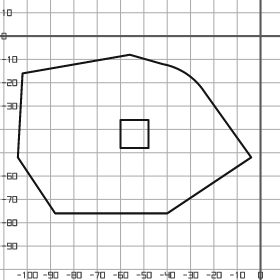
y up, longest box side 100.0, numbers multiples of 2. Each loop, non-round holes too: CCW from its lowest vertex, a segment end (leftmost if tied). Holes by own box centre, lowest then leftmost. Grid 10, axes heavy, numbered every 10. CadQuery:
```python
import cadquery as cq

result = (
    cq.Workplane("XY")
    .moveTo(-88.0, -76.0)
    .lineTo(-40.0, -76.0)
    .lineTo(-4.0, -52.0)
    .lineTo(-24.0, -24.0)
    .threePointArc((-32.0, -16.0), (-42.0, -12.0))
    .lineTo(-56.0, -8.0)
    .lineTo(-102.0, -16.0)
    .lineTo(-104.0, -52.0)
    .close()
    .moveTo(-60.0, -48.0)
    .lineTo(-48.0, -48.0)
    .lineTo(-48.0, -36.0)
    .lineTo(-60.0, -36.0)
    .close()
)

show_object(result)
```